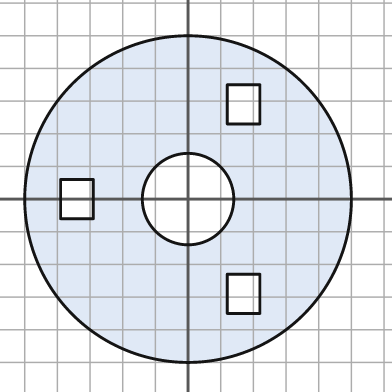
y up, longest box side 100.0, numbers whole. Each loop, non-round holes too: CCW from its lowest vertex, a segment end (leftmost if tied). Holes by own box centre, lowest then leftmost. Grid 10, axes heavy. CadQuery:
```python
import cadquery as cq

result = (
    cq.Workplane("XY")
    .moveTo(0.0, 0.0)
    .circle(50.0)
    .moveTo(12.0, -35.0)
    .lineTo(22.0, -35.0)
    .lineTo(22.0, -23.0)
    .lineTo(12.0, -23.0)
    .close()
    .moveTo(-39.0, -6.0)
    .lineTo(-29.0, -6.0)
    .lineTo(-29.0, 6.0)
    .lineTo(-39.0, 6.0)
    .close()
    .moveTo(0.0, 0.0)
    .circle(14.0)
    .moveTo(12.0, 23.0)
    .lineTo(22.0, 23.0)
    .lineTo(22.0, 35.0)
    .lineTo(12.0, 35.0)
    .close()
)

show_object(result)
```